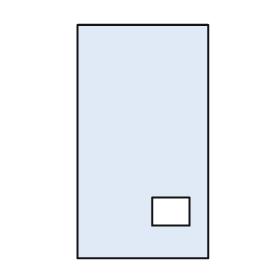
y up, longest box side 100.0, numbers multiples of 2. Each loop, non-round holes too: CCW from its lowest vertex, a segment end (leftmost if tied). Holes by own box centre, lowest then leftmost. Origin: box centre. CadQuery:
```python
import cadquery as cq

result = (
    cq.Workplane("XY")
    .moveTo(-28.0, -50.0)
    .lineTo(28.0, -50.0)
    .lineTo(28.0, 50.0)
    .lineTo(-28.0, 50.0)
    .close()
    .moveTo(4.0, -36.0)
    .lineTo(20.0, -36.0)
    .lineTo(20.0, -24.0)
    .lineTo(4.0, -24.0)
    .close()
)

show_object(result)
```